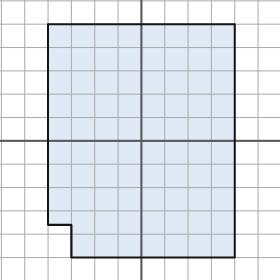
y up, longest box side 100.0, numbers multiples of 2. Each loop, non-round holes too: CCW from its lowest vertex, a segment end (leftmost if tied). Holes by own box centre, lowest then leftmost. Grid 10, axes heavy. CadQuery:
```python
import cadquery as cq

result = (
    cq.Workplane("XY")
    .moveTo(-30.0, -50.0)
    .lineTo(40.0, -50.0)
    .lineTo(40.0, 50.0)
    .lineTo(-40.0, 50.0)
    .lineTo(-40.0, -36.0)
    .lineTo(-30.0, -36.0)
    .close()
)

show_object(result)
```